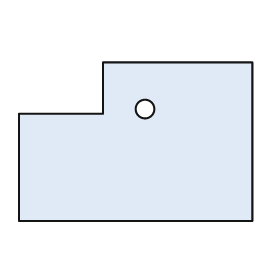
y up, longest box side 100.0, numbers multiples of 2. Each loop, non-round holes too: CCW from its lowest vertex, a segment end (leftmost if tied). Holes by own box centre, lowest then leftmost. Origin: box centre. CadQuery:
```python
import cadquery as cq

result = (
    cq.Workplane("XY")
    .moveTo(-50.0, -34.0)
    .lineTo(50.0, -34.0)
    .lineTo(50.0, 34.0)
    .lineTo(-14.0, 34.0)
    .lineTo(-14.0, 12.0)
    .lineTo(-50.0, 12.0)
    .close()
    .moveTo(4.0, 14.0)
    .circle(4.0)
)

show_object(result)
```